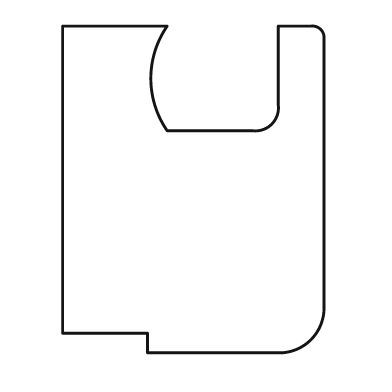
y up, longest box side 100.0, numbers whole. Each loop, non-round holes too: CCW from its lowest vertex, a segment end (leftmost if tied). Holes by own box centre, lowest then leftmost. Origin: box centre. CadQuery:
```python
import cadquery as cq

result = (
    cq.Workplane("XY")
    .moveTo(-14.0, -50.0)
    .lineTo(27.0, -50.0)
    .threePointArc((36.0, -46.0), (40.0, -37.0))
    .lineTo(40.0, 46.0)
    .threePointArc((39.0, 49.0), (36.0, 50.0))
    .lineTo(26.0, 50.0)
    .lineTo(26.0, 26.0)
    .threePointArc((24.0, 20.0), (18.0, 18.0))
    .lineTo(-8.0, 18.0)
    .threePointArc((-13.0, 34.0), (-8.0, 50.0))
    .lineTo(-40.0, 50.0)
    .lineTo(-40.0, -44.0)
    .lineTo(-14.0, -44.0)
    .close()
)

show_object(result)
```